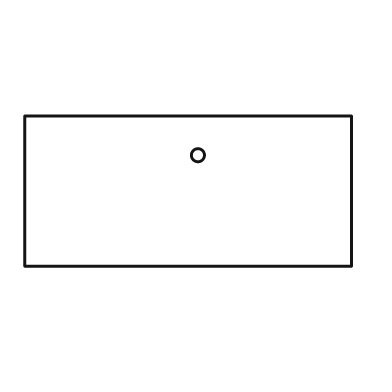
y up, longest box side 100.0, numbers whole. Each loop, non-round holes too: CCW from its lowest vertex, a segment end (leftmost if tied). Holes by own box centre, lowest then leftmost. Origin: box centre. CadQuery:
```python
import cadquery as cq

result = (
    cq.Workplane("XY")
    .moveTo(-50.0, -23.0)
    .lineTo(50.0, -23.0)
    .lineTo(50.0, 23.0)
    .lineTo(-50.0, 23.0)
    .close()
    .moveTo(3.0, 11.0)
    .circle(2.0)
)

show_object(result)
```